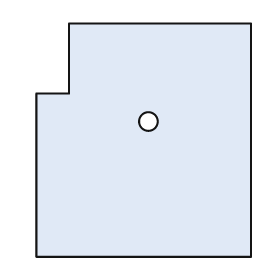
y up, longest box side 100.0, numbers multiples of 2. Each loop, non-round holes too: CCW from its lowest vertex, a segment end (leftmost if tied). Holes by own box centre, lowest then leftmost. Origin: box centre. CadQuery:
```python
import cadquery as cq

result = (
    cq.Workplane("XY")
    .moveTo(-46.0, -50.0)
    .lineTo(46.0, -50.0)
    .lineTo(46.0, 50.0)
    .lineTo(-32.0, 50.0)
    .lineTo(-32.0, 20.0)
    .lineTo(-46.0, 20.0)
    .close()
    .moveTo(2.0, 8.0)
    .circle(4.0)
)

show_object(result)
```